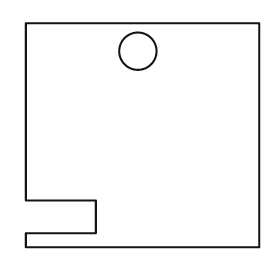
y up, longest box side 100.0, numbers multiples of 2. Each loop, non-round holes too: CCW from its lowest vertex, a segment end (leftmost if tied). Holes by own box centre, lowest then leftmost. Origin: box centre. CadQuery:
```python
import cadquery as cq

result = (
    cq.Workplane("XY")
    .moveTo(-50.0, -48.0)
    .lineTo(50.0, -48.0)
    .lineTo(50.0, 48.0)
    .lineTo(-50.0, 48.0)
    .lineTo(-50.0, -28.0)
    .lineTo(-20.0, -28.0)
    .lineTo(-20.0, -42.0)
    .lineTo(-50.0, -42.0)
    .close()
    .moveTo(-2.0, 36.0)
    .circle(8.0)
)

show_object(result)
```